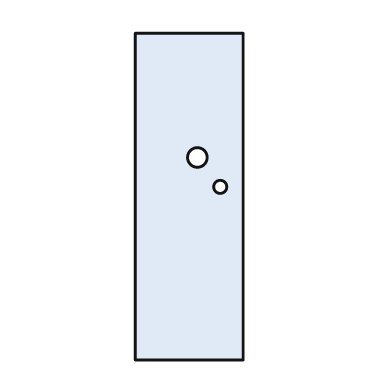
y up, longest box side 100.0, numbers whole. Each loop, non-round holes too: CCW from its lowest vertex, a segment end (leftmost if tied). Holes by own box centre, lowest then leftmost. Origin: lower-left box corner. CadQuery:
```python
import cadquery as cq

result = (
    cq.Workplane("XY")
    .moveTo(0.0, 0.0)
    .lineTo(33.0, 0.0)
    .lineTo(33.0, 100.0)
    .lineTo(0.0, 100.0)
    .close()
    .moveTo(26.0, 53.0)
    .circle(2.0)
    .moveTo(19.0, 62.0)
    .circle(3.0)
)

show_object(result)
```